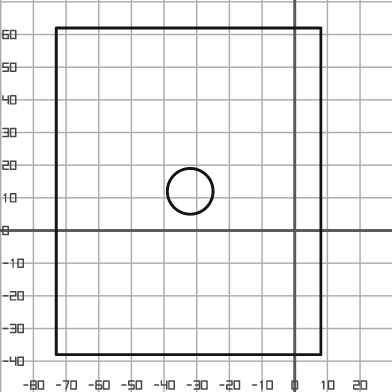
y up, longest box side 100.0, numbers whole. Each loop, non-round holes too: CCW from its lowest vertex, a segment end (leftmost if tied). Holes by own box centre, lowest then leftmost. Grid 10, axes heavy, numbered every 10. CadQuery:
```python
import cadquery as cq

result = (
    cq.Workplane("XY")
    .moveTo(-73.0, -38.0)
    .lineTo(8.0, -38.0)
    .lineTo(8.0, 62.0)
    .lineTo(-73.0, 62.0)
    .close()
    .moveTo(-32.0, 12.0)
    .circle(7.0)
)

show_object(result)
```